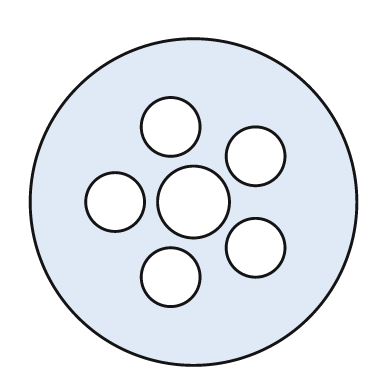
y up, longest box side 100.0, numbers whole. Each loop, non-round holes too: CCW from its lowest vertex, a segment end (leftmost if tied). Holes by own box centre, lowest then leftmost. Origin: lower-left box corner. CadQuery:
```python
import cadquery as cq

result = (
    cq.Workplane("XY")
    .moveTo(50.0, 50.0)
    .circle(50.0)
    .moveTo(43.0, 27.0)
    .circle(9.0)
    .moveTo(69.0, 36.0)
    .circle(9.0)
    .moveTo(26.0, 50.0)
    .circle(9.0)
    .moveTo(50.0, 50.0)
    .circle(11.0)
    .moveTo(69.0, 64.0)
    .circle(9.0)
    .moveTo(43.0, 73.0)
    .circle(9.0)
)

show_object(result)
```